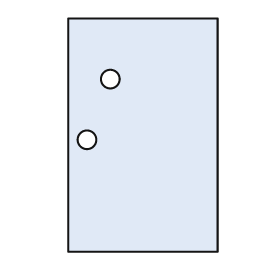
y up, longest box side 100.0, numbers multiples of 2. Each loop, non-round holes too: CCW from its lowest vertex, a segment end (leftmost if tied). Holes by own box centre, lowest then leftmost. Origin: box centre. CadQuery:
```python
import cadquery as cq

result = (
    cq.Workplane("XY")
    .moveTo(-32.0, -50.0)
    .lineTo(32.0, -50.0)
    .lineTo(32.0, 50.0)
    .lineTo(-32.0, 50.0)
    .close()
    .moveTo(-24.0, -2.0)
    .circle(4.0)
    .moveTo(-14.0, 24.0)
    .circle(4.0)
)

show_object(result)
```